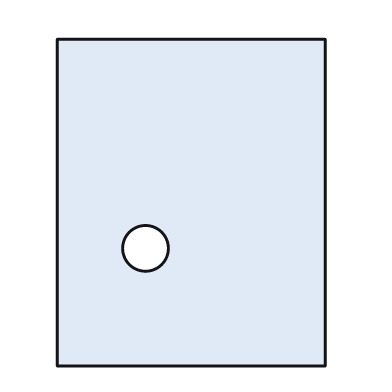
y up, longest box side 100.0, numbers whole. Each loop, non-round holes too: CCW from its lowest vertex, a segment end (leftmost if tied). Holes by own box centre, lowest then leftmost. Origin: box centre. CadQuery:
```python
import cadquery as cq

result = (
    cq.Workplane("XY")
    .moveTo(-41.0, -50.0)
    .lineTo(41.0, -50.0)
    .lineTo(41.0, 50.0)
    .lineTo(-41.0, 50.0)
    .close()
    .moveTo(-14.0, -14.0)
    .circle(7.0)
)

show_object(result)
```